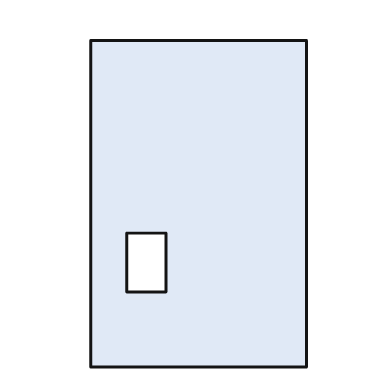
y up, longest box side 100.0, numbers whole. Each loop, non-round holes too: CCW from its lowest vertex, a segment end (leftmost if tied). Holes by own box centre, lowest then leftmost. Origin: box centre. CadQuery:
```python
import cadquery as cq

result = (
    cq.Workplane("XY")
    .moveTo(-33.0, -50.0)
    .lineTo(33.0, -50.0)
    .lineTo(33.0, 50.0)
    .lineTo(-33.0, 50.0)
    .close()
    .moveTo(-22.0, -27.0)
    .lineTo(-10.0, -27.0)
    .lineTo(-10.0, -9.0)
    .lineTo(-22.0, -9.0)
    .close()
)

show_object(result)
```